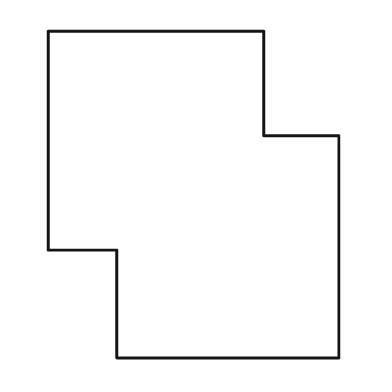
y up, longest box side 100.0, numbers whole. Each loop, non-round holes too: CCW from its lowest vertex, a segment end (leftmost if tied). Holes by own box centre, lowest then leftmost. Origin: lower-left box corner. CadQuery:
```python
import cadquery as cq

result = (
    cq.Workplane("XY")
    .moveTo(21.0, 0.0)
    .lineTo(89.0, 0.0)
    .lineTo(89.0, 68.0)
    .lineTo(66.0, 68.0)
    .lineTo(66.0, 100.0)
    .lineTo(0.0, 100.0)
    .lineTo(0.0, 33.0)
    .lineTo(21.0, 33.0)
    .close()
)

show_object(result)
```